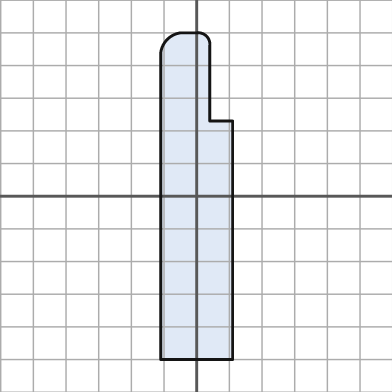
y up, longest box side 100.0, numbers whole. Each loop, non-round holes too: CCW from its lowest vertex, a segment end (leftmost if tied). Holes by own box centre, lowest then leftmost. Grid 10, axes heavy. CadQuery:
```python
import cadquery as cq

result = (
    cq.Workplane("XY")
    .moveTo(-11.0, -50.0)
    .lineTo(11.0, -50.0)
    .lineTo(11.0, 23.0)
    .lineTo(4.0, 23.0)
    .lineTo(4.0, 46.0)
    .threePointArc((3.0, 49.0), (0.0, 50.0))
    .lineTo(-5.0, 50.0)
    .threePointArc((-9.0, 48.0), (-11.0, 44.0))
    .close()
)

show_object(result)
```